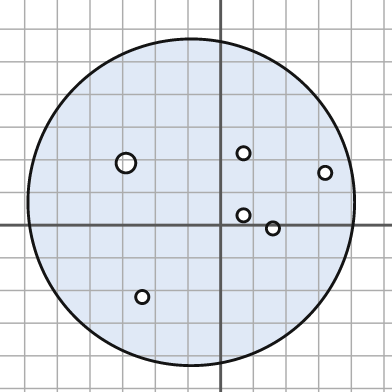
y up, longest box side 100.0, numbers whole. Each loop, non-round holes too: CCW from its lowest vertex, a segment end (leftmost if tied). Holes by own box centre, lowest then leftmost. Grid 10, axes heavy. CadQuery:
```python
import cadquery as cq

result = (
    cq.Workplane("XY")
    .moveTo(-9.0, 7.0)
    .circle(50.0)
    .moveTo(-24.0, -22.0)
    .circle(2.0)
    .moveTo(16.0, -1.0)
    .circle(2.0)
    .moveTo(7.0, 3.0)
    .circle(2.0)
    .moveTo(32.0, 16.0)
    .circle(2.0)
    .moveTo(-29.0, 19.0)
    .circle(3.0)
    .moveTo(7.0, 22.0)
    .circle(2.0)
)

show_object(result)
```